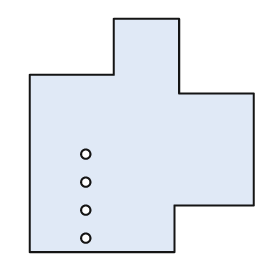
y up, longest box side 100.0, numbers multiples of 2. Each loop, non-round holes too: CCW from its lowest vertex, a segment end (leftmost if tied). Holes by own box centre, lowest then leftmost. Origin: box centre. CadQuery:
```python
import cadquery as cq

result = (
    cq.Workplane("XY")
    .moveTo(-48.0, -50.0)
    .lineTo(14.0, -50.0)
    .lineTo(14.0, -30.0)
    .lineTo(48.0, -30.0)
    .lineTo(48.0, 18.0)
    .lineTo(16.0, 18.0)
    .lineTo(16.0, 50.0)
    .lineTo(-12.0, 50.0)
    .lineTo(-12.0, 26.0)
    .lineTo(-48.0, 26.0)
    .close()
    .moveTo(-24.0, -44.0)
    .circle(2.0)
    .moveTo(-24.0, -32.0)
    .circle(2.0)
    .moveTo(-24.0, -20.0)
    .circle(2.0)
    .moveTo(-24.0, -8.0)
    .circle(2.0)
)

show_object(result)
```